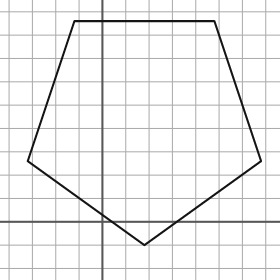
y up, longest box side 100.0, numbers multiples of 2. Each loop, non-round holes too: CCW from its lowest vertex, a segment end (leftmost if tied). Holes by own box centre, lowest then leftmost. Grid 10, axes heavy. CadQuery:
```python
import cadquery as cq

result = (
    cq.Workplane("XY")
    .moveTo(18.0, -10.0)
    .lineTo(68.0, 26.0)
    .lineTo(48.0, 86.0)
    .lineTo(-12.0, 86.0)
    .lineTo(-32.0, 26.0)
    .close()
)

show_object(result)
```